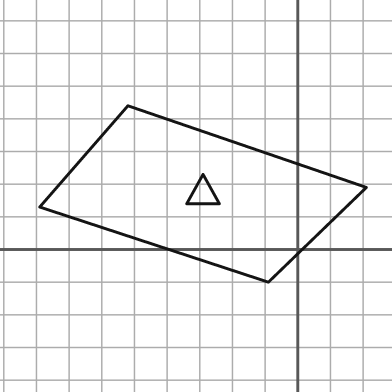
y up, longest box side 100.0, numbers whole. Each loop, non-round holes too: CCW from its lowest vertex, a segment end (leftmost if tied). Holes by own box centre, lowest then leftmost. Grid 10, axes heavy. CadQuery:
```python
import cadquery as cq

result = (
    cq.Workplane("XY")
    .moveTo(-9.0, -10.0)
    .lineTo(21.0, 19.0)
    .lineTo(-52.0, 44.0)
    .lineTo(-79.0, 13.0)
    .close()
    .moveTo(-34.0, 14.0)
    .lineTo(-24.0, 14.0)
    .lineTo(-29.0, 23.0)
    .close()
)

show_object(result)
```